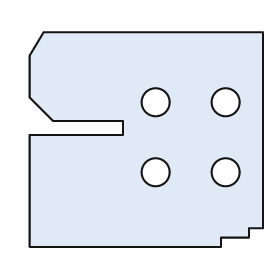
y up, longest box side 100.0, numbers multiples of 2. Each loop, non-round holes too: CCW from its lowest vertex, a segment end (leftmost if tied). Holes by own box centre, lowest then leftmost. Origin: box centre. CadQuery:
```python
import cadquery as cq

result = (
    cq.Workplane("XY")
    .moveTo(-50.0, -46.0)
    .lineTo(32.0, -46.0)
    .lineTo(32.0, -42.0)
    .lineTo(44.0, -42.0)
    .lineTo(44.0, -38.0)
    .lineTo(50.0, -38.0)
    .lineTo(50.0, 46.0)
    .lineTo(-44.0, 46.0)
    .lineTo(-50.0, 36.0)
    .lineTo(-50.0, 18.0)
    .lineTo(-40.0, 8.0)
    .lineTo(-10.0, 8.0)
    .lineTo(-10.0, 2.0)
    .lineTo(-50.0, 2.0)
    .close()
    .moveTo(4.0, -14.0)
    .circle(6.0)
    .moveTo(34.0, -14.0)
    .circle(6.0)
    .moveTo(4.0, 16.0)
    .circle(6.0)
    .moveTo(34.0, 16.0)
    .circle(6.0)
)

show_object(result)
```